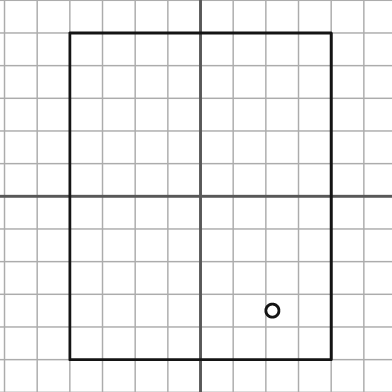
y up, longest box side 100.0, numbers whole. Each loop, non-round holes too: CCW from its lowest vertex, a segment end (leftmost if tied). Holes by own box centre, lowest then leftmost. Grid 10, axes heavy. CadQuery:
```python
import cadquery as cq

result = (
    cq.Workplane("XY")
    .moveTo(-40.0, -50.0)
    .lineTo(40.0, -50.0)
    .lineTo(40.0, 50.0)
    .lineTo(-40.0, 50.0)
    .close()
    .moveTo(22.0, -35.0)
    .circle(2.0)
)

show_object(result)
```